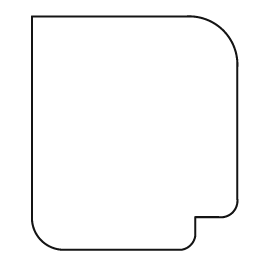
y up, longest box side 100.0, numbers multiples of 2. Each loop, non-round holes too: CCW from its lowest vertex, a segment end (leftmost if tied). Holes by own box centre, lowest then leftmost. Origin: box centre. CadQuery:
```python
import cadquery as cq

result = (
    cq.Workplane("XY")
    .moveTo(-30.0, -50.0)
    .lineTo(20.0, -50.0)
    .threePointArc((24.0, -48.0), (26.0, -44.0))
    .lineTo(26.0, -36.0)
    .lineTo(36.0, -36.0)
    .threePointArc((42.0, -34.0), (44.0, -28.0))
    .lineTo(44.0, 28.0)
    .threePointArc((38.0, 44.0), (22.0, 50.0))
    .lineTo(-44.0, 50.0)
    .lineTo(-44.0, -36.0)
    .threePointArc((-40.0, -46.0), (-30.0, -50.0))
    .close()
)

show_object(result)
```